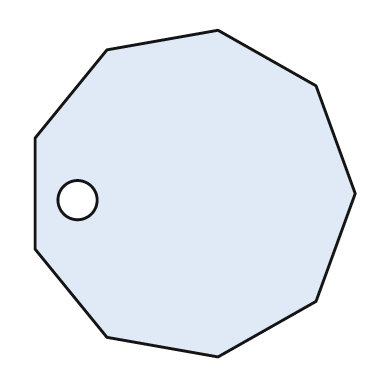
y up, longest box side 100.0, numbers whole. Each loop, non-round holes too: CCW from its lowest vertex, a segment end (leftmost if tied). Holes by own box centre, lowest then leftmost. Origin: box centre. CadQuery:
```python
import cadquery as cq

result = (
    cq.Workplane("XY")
    .moveTo(7.0, -50.0)
    .lineTo(37.0, -33.0)
    .lineTo(49.0, 0.0)
    .lineTo(37.0, 33.0)
    .lineTo(7.0, 50.0)
    .lineTo(-27.0, 44.0)
    .lineTo(-49.0, 17.0)
    .lineTo(-49.0, -17.0)
    .lineTo(-27.0, -44.0)
    .close()
    .moveTo(-36.0, -2.0)
    .circle(6.0)
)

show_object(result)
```